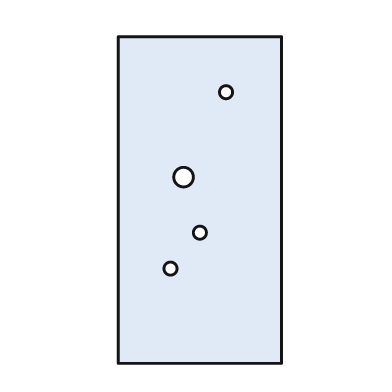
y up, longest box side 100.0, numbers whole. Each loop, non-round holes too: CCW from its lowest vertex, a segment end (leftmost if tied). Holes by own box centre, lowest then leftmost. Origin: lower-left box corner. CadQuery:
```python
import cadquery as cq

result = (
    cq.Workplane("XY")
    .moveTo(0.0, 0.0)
    .lineTo(50.0, 0.0)
    .lineTo(50.0, 100.0)
    .lineTo(0.0, 100.0)
    .close()
    .moveTo(16.0, 29.0)
    .circle(2.0)
    .moveTo(25.0, 40.0)
    .circle(2.0)
    .moveTo(20.0, 57.0)
    .circle(3.0)
    .moveTo(33.0, 83.0)
    .circle(2.0)
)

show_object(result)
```